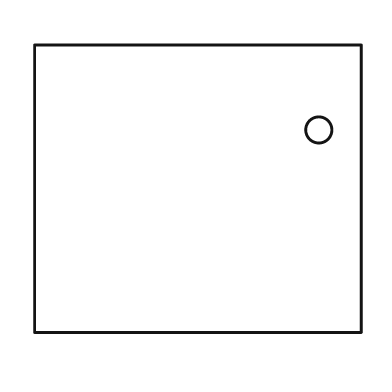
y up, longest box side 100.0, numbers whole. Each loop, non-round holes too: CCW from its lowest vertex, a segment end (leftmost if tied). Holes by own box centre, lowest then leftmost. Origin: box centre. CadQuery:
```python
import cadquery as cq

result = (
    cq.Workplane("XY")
    .moveTo(-50.0, -44.0)
    .lineTo(50.0, -44.0)
    .lineTo(50.0, 44.0)
    .lineTo(-50.0, 44.0)
    .close()
    .moveTo(37.0, 18.0)
    .circle(4.0)
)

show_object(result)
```